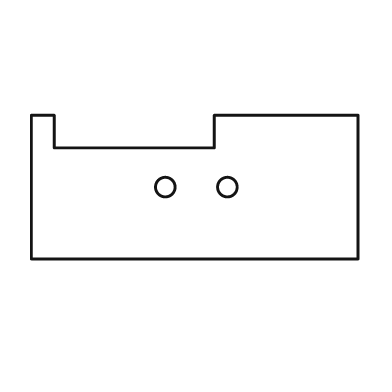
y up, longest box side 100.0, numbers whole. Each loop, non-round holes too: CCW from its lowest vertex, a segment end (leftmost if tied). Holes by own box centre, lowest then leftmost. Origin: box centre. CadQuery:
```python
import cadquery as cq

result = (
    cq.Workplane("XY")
    .moveTo(-50.0, -22.0)
    .lineTo(50.0, -22.0)
    .lineTo(50.0, 22.0)
    .lineTo(6.0, 22.0)
    .lineTo(6.0, 12.0)
    .lineTo(-43.0, 12.0)
    .lineTo(-43.0, 22.0)
    .lineTo(-50.0, 22.0)
    .close()
    .moveTo(-9.0, 0.0)
    .circle(3.0)
    .moveTo(10.0, 0.0)
    .circle(3.0)
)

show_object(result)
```